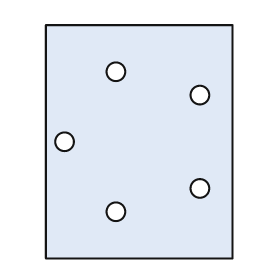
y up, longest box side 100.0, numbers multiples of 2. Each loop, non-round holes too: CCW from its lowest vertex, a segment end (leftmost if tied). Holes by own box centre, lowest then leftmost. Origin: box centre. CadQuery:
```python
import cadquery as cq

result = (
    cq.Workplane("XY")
    .moveTo(-40.0, -50.0)
    .lineTo(40.0, -50.0)
    .lineTo(40.0, 50.0)
    .lineTo(-40.0, 50.0)
    .close()
    .moveTo(-10.0, -30.0)
    .circle(4.0)
    .moveTo(26.0, -20.0)
    .circle(4.0)
    .moveTo(-32.0, 0.0)
    .circle(4.0)
    .moveTo(26.0, 20.0)
    .circle(4.0)
    .moveTo(-10.0, 30.0)
    .circle(4.0)
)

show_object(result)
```